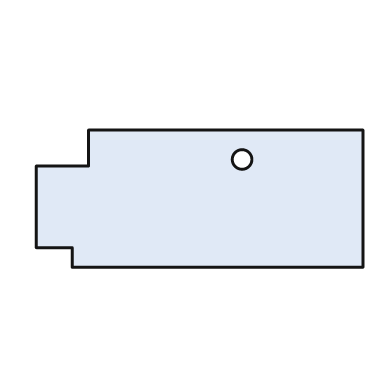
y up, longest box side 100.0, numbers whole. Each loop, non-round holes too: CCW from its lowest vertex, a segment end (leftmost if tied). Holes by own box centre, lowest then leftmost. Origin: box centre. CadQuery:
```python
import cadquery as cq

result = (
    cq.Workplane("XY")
    .moveTo(-39.0, -21.0)
    .lineTo(50.0, -21.0)
    .lineTo(50.0, 21.0)
    .lineTo(-34.0, 21.0)
    .lineTo(-34.0, 10.0)
    .lineTo(-50.0, 10.0)
    .lineTo(-50.0, -15.0)
    .lineTo(-39.0, -15.0)
    .close()
    .moveTo(13.0, 12.0)
    .circle(3.0)
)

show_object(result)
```